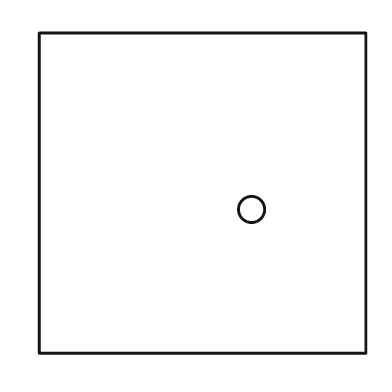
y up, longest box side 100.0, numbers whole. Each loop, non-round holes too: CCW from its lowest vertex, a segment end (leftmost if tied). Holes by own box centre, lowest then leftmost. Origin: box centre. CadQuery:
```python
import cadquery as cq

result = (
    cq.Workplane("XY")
    .moveTo(-50.0, -49.0)
    .lineTo(50.0, -49.0)
    .lineTo(50.0, 49.0)
    .lineTo(-50.0, 49.0)
    .close()
    .moveTo(15.0, -5.0)
    .circle(4.0)
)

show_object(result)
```